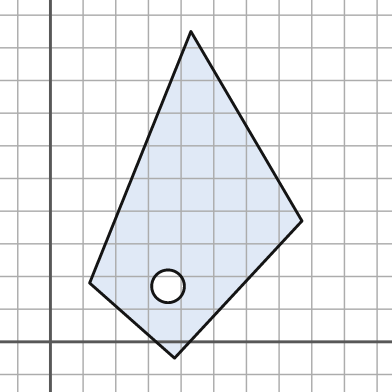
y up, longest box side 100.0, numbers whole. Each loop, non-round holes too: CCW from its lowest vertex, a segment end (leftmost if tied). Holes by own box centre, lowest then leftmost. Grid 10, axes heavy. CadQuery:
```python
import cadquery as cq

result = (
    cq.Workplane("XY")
    .moveTo(38.0, -5.0)
    .lineTo(77.0, 37.0)
    .lineTo(43.0, 95.0)
    .lineTo(12.0, 18.0)
    .close()
    .moveTo(36.0, 17.0)
    .circle(5.0)
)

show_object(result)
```